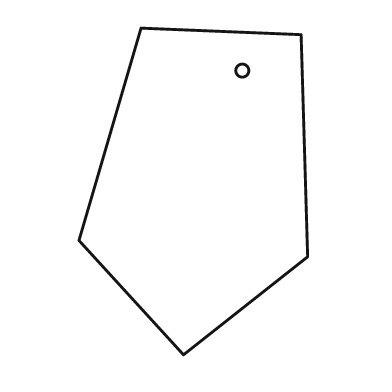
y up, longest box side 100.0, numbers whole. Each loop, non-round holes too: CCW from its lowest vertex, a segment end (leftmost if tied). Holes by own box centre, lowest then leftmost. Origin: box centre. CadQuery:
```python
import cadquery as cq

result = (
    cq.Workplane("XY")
    .moveTo(-3.0, -50.0)
    .lineTo(35.0, -20.0)
    .lineTo(33.0, 48.0)
    .lineTo(-16.0, 50.0)
    .lineTo(-35.0, -15.0)
    .close()
    .moveTo(15.0, 37.0)
    .circle(2.0)
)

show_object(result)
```